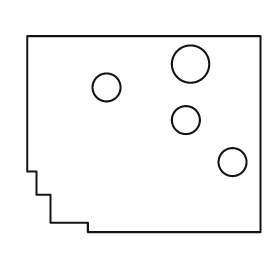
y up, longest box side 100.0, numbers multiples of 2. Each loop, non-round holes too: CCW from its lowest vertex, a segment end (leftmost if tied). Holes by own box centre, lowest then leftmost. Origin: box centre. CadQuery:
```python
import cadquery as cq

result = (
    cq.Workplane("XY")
    .moveTo(-24.0, -42.0)
    .lineTo(50.0, -42.0)
    .lineTo(50.0, 42.0)
    .lineTo(-50.0, 42.0)
    .lineTo(-50.0, -16.0)
    .lineTo(-46.0, -16.0)
    .lineTo(-46.0, -26.0)
    .lineTo(-40.0, -26.0)
    .lineTo(-40.0, -38.0)
    .lineTo(-24.0, -38.0)
    .close()
    .moveTo(38.0, -12.0)
    .circle(6.0)
    .moveTo(18.0, 6.0)
    .circle(6.0)
    .moveTo(-16.0, 20.0)
    .circle(6.0)
    .moveTo(20.0, 30.0)
    .circle(8.0)
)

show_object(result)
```